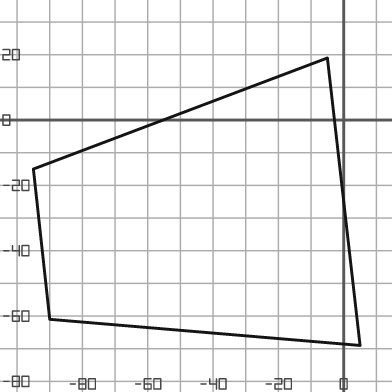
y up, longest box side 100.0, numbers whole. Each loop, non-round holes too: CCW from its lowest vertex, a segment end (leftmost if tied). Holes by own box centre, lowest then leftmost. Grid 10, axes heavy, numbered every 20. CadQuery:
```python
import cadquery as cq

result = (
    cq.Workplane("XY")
    .moveTo(5.0, -69.0)
    .lineTo(-5.0, 19.0)
    .lineTo(-95.0, -15.0)
    .lineTo(-90.0, -61.0)
    .close()
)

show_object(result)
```